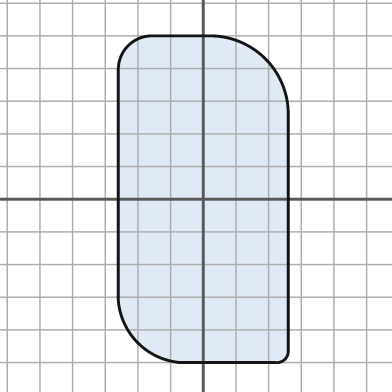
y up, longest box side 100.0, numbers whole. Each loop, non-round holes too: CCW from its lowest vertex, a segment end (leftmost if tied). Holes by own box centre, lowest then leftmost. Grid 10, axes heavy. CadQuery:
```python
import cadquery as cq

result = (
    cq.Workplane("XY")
    .moveTo(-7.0, -50.0)
    .lineTo(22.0, -50.0)
    .threePointArc((25.0, -49.0), (26.0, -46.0))
    .lineTo(26.0, 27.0)
    .threePointArc((19.0, 43.0), (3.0, 50.0))
    .lineTo(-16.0, 50.0)
    .threePointArc((-23.0, 47.0), (-26.0, 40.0))
    .lineTo(-26.0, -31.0)
    .threePointArc((-20.0, -44.0), (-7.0, -50.0))
    .close()
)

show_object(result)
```